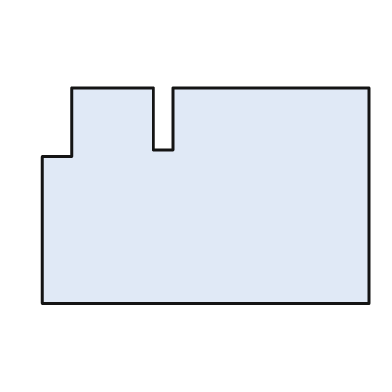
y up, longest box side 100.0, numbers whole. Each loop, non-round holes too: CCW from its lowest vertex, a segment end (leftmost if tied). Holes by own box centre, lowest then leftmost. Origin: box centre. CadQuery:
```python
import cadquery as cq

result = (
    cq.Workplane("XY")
    .moveTo(-50.0, -33.0)
    .lineTo(50.0, -33.0)
    .lineTo(50.0, 33.0)
    .lineTo(-10.0, 33.0)
    .lineTo(-10.0, 14.0)
    .lineTo(-16.0, 14.0)
    .lineTo(-16.0, 33.0)
    .lineTo(-41.0, 33.0)
    .lineTo(-41.0, 12.0)
    .lineTo(-50.0, 12.0)
    .close()
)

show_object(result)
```